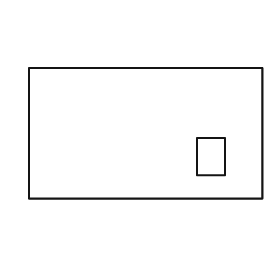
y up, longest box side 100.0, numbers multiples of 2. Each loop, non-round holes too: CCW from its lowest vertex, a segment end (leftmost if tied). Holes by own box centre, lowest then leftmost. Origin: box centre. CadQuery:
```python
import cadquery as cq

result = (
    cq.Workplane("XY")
    .moveTo(-50.0, -28.0)
    .lineTo(50.0, -28.0)
    .lineTo(50.0, 28.0)
    .lineTo(-50.0, 28.0)
    .close()
    .moveTo(22.0, -18.0)
    .lineTo(34.0, -18.0)
    .lineTo(34.0, -2.0)
    .lineTo(22.0, -2.0)
    .close()
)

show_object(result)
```